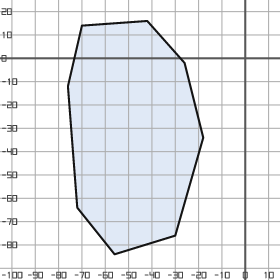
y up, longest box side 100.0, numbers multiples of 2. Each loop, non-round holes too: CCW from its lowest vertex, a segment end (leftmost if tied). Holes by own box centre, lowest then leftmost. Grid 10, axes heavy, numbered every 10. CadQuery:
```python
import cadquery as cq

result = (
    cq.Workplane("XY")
    .moveTo(-56.0, -84.0)
    .lineTo(-30.0, -76.0)
    .lineTo(-18.0, -34.0)
    .lineTo(-26.0, -2.0)
    .lineTo(-42.0, 16.0)
    .lineTo(-70.0, 14.0)
    .lineTo(-76.0, -12.0)
    .lineTo(-72.0, -64.0)
    .close()
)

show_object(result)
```